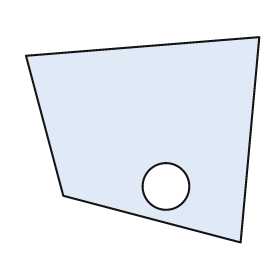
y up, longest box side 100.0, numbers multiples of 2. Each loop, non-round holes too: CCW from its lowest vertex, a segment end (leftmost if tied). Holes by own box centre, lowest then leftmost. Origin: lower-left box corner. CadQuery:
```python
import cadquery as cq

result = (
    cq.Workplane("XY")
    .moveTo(92.0, 0.0)
    .lineTo(100.0, 88.0)
    .lineTo(0.0, 80.0)
    .lineTo(16.0, 20.0)
    .close()
    .moveTo(60.0, 24.0)
    .circle(10.0)
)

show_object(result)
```